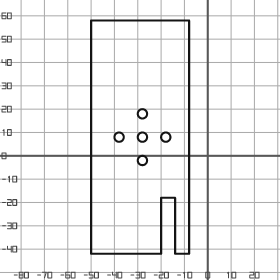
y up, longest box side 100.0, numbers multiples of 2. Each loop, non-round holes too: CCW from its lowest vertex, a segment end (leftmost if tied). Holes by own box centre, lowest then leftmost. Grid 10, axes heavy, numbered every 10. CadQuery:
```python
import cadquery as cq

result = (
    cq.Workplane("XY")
    .moveTo(-50.0, -42.0)
    .lineTo(-20.0, -42.0)
    .lineTo(-20.0, -18.0)
    .lineTo(-14.0, -18.0)
    .lineTo(-14.0, -42.0)
    .lineTo(-8.0, -42.0)
    .lineTo(-8.0, 58.0)
    .lineTo(-50.0, 58.0)
    .close()
    .moveTo(-28.0, -2.0)
    .circle(2.0)
    .moveTo(-38.0, 8.0)
    .circle(2.0)
    .moveTo(-28.0, 8.0)
    .circle(2.0)
    .moveTo(-18.0, 8.0)
    .circle(2.0)
    .moveTo(-28.0, 18.0)
    .circle(2.0)
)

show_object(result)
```